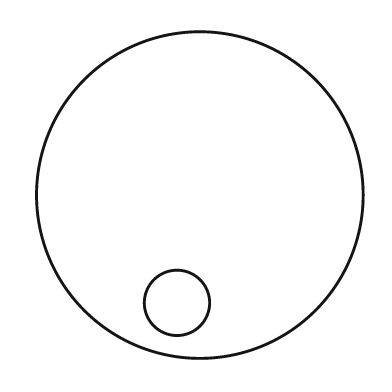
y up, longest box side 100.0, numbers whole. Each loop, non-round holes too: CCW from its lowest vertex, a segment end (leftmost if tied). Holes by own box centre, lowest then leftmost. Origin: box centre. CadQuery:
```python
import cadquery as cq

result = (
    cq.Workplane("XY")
    .moveTo(0.0, 0.0)
    .circle(50.0)
    .moveTo(-7.0, -33.0)
    .circle(10.0)
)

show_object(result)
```